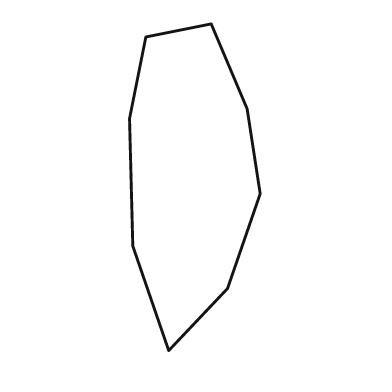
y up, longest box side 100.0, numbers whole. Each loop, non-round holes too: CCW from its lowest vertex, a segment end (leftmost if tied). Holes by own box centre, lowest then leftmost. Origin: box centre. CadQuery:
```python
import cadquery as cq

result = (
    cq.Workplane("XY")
    .moveTo(-8.0, -50.0)
    .lineTo(10.0, -31.0)
    .lineTo(20.0, -2.0)
    .lineTo(16.0, 24.0)
    .lineTo(5.0, 50.0)
    .lineTo(-15.0, 46.0)
    .lineTo(-20.0, 21.0)
    .lineTo(-19.0, -18.0)
    .close()
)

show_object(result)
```